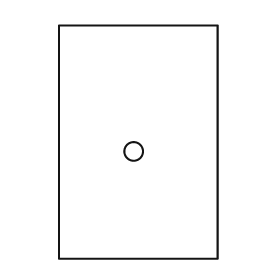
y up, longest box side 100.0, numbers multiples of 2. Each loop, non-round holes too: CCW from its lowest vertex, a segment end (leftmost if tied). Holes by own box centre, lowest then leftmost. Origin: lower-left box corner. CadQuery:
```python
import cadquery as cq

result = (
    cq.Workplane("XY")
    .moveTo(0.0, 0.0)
    .lineTo(68.0, 0.0)
    .lineTo(68.0, 100.0)
    .lineTo(0.0, 100.0)
    .close()
    .moveTo(32.0, 46.0)
    .circle(4.0)
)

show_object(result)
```